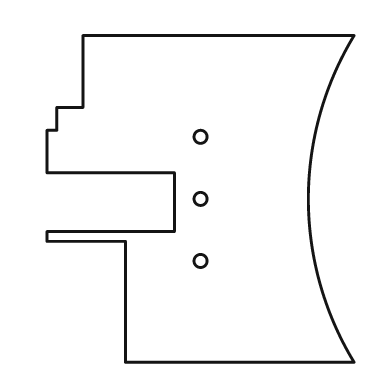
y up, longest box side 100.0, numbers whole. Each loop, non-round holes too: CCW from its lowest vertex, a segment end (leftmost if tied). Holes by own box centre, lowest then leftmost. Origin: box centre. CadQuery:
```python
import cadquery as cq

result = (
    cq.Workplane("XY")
    .moveTo(-23.0, -50.0)
    .lineTo(47.0, -50.0)
    .threePointArc((33.0, 0.0), (47.0, 50.0))
    .lineTo(-36.0, 50.0)
    .lineTo(-36.0, 28.0)
    .lineTo(-44.0, 28.0)
    .lineTo(-44.0, 21.0)
    .lineTo(-47.0, 21.0)
    .lineTo(-47.0, 8.0)
    .lineTo(-8.0, 8.0)
    .lineTo(-8.0, -10.0)
    .lineTo(-47.0, -10.0)
    .lineTo(-47.0, -13.0)
    .lineTo(-23.0, -13.0)
    .close()
    .moveTo(0.0, -19.0)
    .circle(2.0)
    .moveTo(0.0, 0.0)
    .circle(2.0)
    .moveTo(0.0, 19.0)
    .circle(2.0)
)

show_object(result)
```